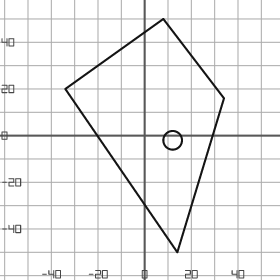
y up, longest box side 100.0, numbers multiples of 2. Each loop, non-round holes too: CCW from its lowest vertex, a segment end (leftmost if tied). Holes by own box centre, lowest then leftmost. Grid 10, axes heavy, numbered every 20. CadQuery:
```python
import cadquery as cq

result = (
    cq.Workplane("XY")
    .moveTo(14.0, -50.0)
    .lineTo(34.0, 16.0)
    .lineTo(8.0, 50.0)
    .lineTo(-34.0, 20.0)
    .close()
    .moveTo(12.0, -2.0)
    .circle(4.0)
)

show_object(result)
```